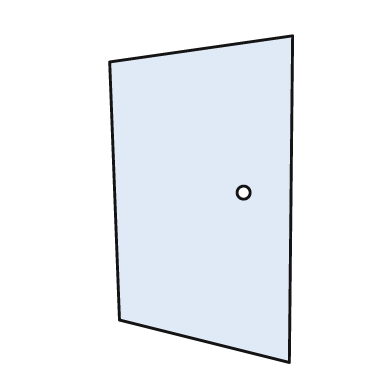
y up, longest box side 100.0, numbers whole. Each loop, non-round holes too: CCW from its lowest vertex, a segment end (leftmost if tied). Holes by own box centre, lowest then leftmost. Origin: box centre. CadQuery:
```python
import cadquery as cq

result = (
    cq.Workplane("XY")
    .moveTo(27.0, -50.0)
    .lineTo(28.0, 50.0)
    .lineTo(-28.0, 42.0)
    .lineTo(-25.0, -37.0)
    .close()
    .moveTo(13.0, 2.0)
    .circle(2.0)
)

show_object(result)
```